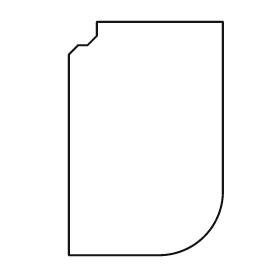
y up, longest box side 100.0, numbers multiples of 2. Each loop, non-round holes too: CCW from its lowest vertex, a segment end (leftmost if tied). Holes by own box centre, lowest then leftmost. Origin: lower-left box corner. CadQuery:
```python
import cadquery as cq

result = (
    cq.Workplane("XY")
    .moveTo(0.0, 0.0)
    .lineTo(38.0, 0.0)
    .threePointArc((58.0, 8.0), (66.0, 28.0))
    .lineTo(66.0, 100.0)
    .lineTo(12.0, 100.0)
    .lineTo(12.0, 94.0)
    .lineTo(8.0, 90.0)
    .lineTo(4.0, 90.0)
    .lineTo(0.0, 86.0)
    .close()
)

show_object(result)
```